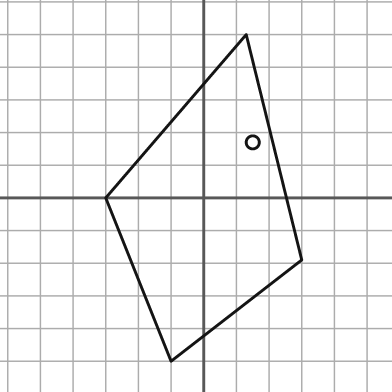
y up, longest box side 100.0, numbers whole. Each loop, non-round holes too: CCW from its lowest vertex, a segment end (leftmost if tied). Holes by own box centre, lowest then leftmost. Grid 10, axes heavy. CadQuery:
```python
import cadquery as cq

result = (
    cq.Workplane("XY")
    .moveTo(-10.0, -50.0)
    .lineTo(30.0, -19.0)
    .lineTo(13.0, 50.0)
    .lineTo(-30.0, 0.0)
    .close()
    .moveTo(15.0, 17.0)
    .circle(2.0)
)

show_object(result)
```